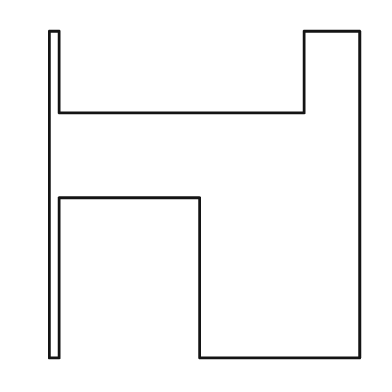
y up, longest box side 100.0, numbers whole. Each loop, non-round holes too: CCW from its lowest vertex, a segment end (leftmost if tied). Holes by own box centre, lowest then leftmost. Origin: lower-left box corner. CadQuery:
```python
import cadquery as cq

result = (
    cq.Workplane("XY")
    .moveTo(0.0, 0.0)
    .lineTo(3.0, 0.0)
    .lineTo(3.0, 49.0)
    .lineTo(46.0, 49.0)
    .lineTo(46.0, 0.0)
    .lineTo(95.0, 0.0)
    .lineTo(95.0, 100.0)
    .lineTo(78.0, 100.0)
    .lineTo(78.0, 75.0)
    .lineTo(3.0, 75.0)
    .lineTo(3.0, 100.0)
    .lineTo(0.0, 100.0)
    .close()
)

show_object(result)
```